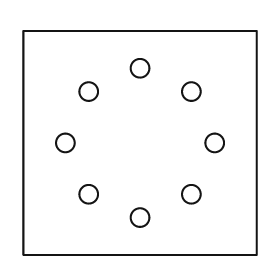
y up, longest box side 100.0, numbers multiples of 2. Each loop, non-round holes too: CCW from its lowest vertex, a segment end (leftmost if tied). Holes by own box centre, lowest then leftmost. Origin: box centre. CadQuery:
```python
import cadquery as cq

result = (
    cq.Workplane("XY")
    .moveTo(-50.0, -48.0)
    .lineTo(50.0, -48.0)
    .lineTo(50.0, 48.0)
    .lineTo(-50.0, 48.0)
    .close()
    .moveTo(0.0, -32.0)
    .circle(4.0)
    .moveTo(-22.0, -22.0)
    .circle(4.0)
    .moveTo(22.0, -22.0)
    .circle(4.0)
    .moveTo(-32.0, 0.0)
    .circle(4.0)
    .moveTo(32.0, 0.0)
    .circle(4.0)
    .moveTo(-22.0, 22.0)
    .circle(4.0)
    .moveTo(22.0, 22.0)
    .circle(4.0)
    .moveTo(0.0, 32.0)
    .circle(4.0)
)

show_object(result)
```